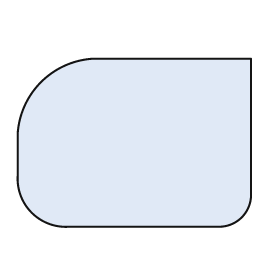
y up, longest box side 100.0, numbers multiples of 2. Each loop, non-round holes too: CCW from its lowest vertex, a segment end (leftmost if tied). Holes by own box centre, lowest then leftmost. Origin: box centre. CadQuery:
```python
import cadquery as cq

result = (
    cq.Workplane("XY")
    .moveTo(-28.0, -36.0)
    .lineTo(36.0, -36.0)
    .threePointArc((46.0, -32.0), (50.0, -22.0))
    .lineTo(50.0, 36.0)
    .lineTo(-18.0, 36.0)
    .threePointArc((-40.0, 26.0), (-50.0, 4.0))
    .lineTo(-50.0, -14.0)
    .threePointArc((-44.0, -30.0), (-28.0, -36.0))
    .close()
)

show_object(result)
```